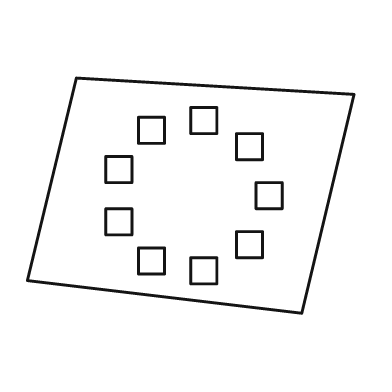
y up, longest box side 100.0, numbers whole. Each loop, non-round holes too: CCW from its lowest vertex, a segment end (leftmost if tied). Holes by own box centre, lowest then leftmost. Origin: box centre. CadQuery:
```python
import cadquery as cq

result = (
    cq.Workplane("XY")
    .moveTo(34.0, -36.0)
    .lineTo(50.0, 31.0)
    .lineTo(-35.0, 36.0)
    .lineTo(-50.0, -26.0)
    .close()
    .moveTo(0.0, -27.0)
    .lineTo(8.0, -27.0)
    .lineTo(8.0, -19.0)
    .lineTo(0.0, -19.0)
    .close()
    .moveTo(-16.0, -24.0)
    .lineTo(-8.0, -24.0)
    .lineTo(-8.0, -16.0)
    .lineTo(-16.0, -16.0)
    .close()
    .moveTo(14.0, -19.0)
    .lineTo(22.0, -19.0)
    .lineTo(22.0, -11.0)
    .lineTo(14.0, -11.0)
    .close()
    .moveTo(-26.0, -12.0)
    .lineTo(-18.0, -12.0)
    .lineTo(-18.0, -4.0)
    .lineTo(-26.0, -4.0)
    .close()
    .moveTo(20.0, -4.0)
    .lineTo(28.0, -4.0)
    .lineTo(28.0, 4.0)
    .lineTo(20.0, 4.0)
    .close()
    .moveTo(-26.0, 4.0)
    .lineTo(-18.0, 4.0)
    .lineTo(-18.0, 12.0)
    .lineTo(-26.0, 12.0)
    .close()
    .moveTo(14.0, 11.0)
    .lineTo(22.0, 11.0)
    .lineTo(22.0, 19.0)
    .lineTo(14.0, 19.0)
    .close()
    .moveTo(-16.0, 16.0)
    .lineTo(-8.0, 16.0)
    .lineTo(-8.0, 24.0)
    .lineTo(-16.0, 24.0)
    .close()
    .moveTo(0.0, 19.0)
    .lineTo(8.0, 19.0)
    .lineTo(8.0, 27.0)
    .lineTo(0.0, 27.0)
    .close()
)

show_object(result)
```